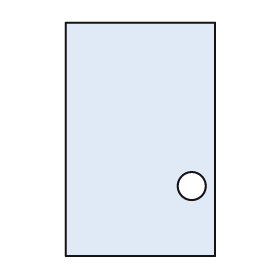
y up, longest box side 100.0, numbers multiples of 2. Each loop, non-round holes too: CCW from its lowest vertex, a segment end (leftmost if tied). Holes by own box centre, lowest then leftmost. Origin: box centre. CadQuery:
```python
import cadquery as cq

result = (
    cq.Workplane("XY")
    .moveTo(-32.0, -50.0)
    .lineTo(32.0, -50.0)
    .lineTo(32.0, 50.0)
    .lineTo(-32.0, 50.0)
    .close()
    .moveTo(22.0, -20.0)
    .circle(6.0)
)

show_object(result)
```